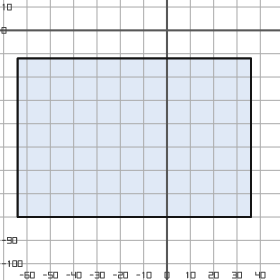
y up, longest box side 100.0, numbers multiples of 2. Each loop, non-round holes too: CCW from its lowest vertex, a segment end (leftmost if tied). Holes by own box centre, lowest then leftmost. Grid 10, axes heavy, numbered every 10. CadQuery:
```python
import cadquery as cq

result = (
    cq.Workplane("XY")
    .moveTo(-64.0, -80.0)
    .lineTo(36.0, -80.0)
    .lineTo(36.0, -12.0)
    .lineTo(-64.0, -12.0)
    .close()
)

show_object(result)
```